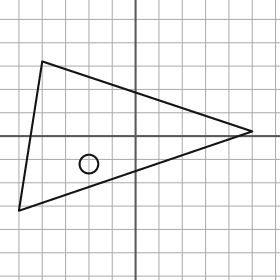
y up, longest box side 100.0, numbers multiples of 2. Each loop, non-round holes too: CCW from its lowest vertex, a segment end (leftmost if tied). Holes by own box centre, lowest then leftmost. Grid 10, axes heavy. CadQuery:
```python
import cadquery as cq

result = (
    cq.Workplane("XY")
    .moveTo(-50.0, -32.0)
    .lineTo(50.0, 2.0)
    .lineTo(-40.0, 32.0)
    .close()
    .moveTo(-20.0, -12.0)
    .circle(4.0)
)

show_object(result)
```